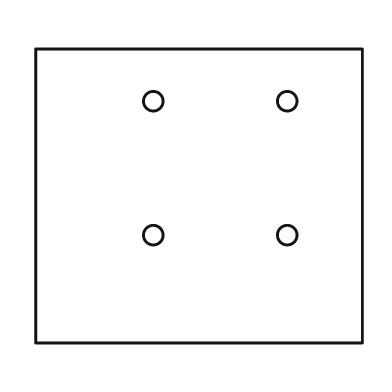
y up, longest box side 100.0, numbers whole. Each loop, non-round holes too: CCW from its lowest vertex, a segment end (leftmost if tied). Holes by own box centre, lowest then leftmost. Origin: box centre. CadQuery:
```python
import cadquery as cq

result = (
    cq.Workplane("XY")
    .moveTo(-50.0, -45.0)
    .lineTo(50.0, -45.0)
    .lineTo(50.0, 45.0)
    .lineTo(-50.0, 45.0)
    .close()
    .moveTo(-14.0, -12.0)
    .circle(3.0)
    .moveTo(27.0, -12.0)
    .circle(3.0)
    .moveTo(-14.0, 29.0)
    .circle(3.0)
    .moveTo(27.0, 29.0)
    .circle(3.0)
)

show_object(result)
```